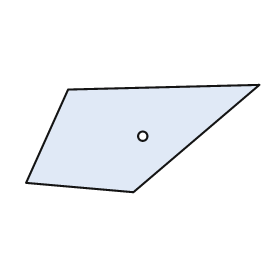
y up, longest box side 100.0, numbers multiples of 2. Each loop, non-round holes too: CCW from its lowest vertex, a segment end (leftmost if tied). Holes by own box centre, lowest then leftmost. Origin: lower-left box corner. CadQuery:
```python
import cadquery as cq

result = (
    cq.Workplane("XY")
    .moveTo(46.0, 0.0)
    .lineTo(100.0, 46.0)
    .lineTo(18.0, 44.0)
    .lineTo(0.0, 4.0)
    .close()
    .moveTo(50.0, 24.0)
    .circle(2.0)
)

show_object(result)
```